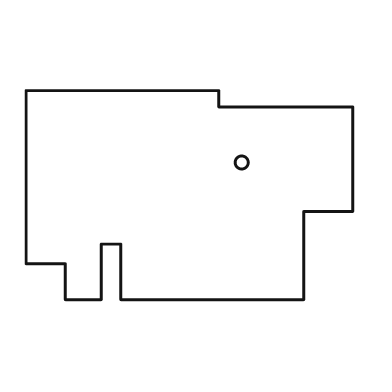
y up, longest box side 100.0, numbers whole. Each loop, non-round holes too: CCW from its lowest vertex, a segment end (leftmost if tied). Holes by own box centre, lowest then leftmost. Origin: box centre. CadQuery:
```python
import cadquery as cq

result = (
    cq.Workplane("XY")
    .moveTo(-38.0, -32.0)
    .lineTo(-27.0, -32.0)
    .lineTo(-27.0, -15.0)
    .lineTo(-21.0, -15.0)
    .lineTo(-21.0, -32.0)
    .lineTo(35.0, -32.0)
    .lineTo(35.0, -5.0)
    .lineTo(50.0, -5.0)
    .lineTo(50.0, 27.0)
    .lineTo(9.0, 27.0)
    .lineTo(9.0, 32.0)
    .lineTo(-50.0, 32.0)
    .lineTo(-50.0, -21.0)
    .lineTo(-38.0, -21.0)
    .close()
    .moveTo(16.0, 10.0)
    .circle(2.0)
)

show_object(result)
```